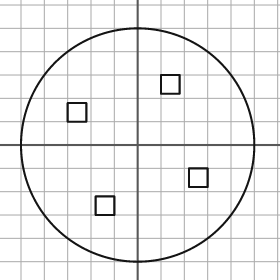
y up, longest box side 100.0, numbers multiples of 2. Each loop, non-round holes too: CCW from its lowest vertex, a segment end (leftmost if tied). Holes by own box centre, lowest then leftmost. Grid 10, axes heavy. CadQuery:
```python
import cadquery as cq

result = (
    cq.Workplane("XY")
    .moveTo(0.0, 0.0)
    .circle(50.0)
    .moveTo(-18.0, -30.0)
    .lineTo(-10.0, -30.0)
    .lineTo(-10.0, -22.0)
    .lineTo(-18.0, -22.0)
    .close()
    .moveTo(22.0, -18.0)
    .lineTo(30.0, -18.0)
    .lineTo(30.0, -10.0)
    .lineTo(22.0, -10.0)
    .close()
    .moveTo(-30.0, 10.0)
    .lineTo(-22.0, 10.0)
    .lineTo(-22.0, 18.0)
    .lineTo(-30.0, 18.0)
    .close()
    .moveTo(10.0, 22.0)
    .lineTo(18.0, 22.0)
    .lineTo(18.0, 30.0)
    .lineTo(10.0, 30.0)
    .close()
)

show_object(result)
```